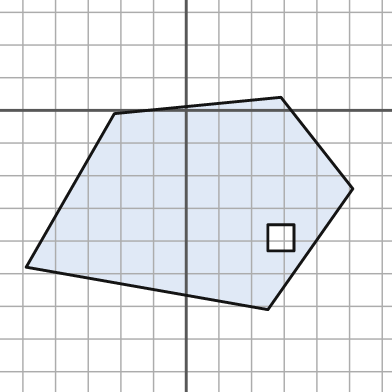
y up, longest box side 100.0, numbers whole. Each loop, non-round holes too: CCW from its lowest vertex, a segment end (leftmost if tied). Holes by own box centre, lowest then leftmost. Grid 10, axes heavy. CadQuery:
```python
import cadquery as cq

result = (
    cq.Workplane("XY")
    .moveTo(25.0, -61.0)
    .lineTo(51.0, -24.0)
    .lineTo(29.0, 4.0)
    .lineTo(-22.0, -1.0)
    .lineTo(-49.0, -48.0)
    .close()
    .moveTo(25.0, -43.0)
    .lineTo(33.0, -43.0)
    .lineTo(33.0, -35.0)
    .lineTo(25.0, -35.0)
    .close()
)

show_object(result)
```